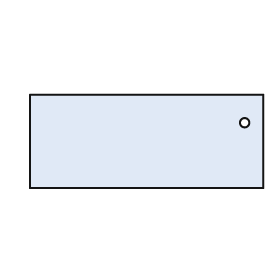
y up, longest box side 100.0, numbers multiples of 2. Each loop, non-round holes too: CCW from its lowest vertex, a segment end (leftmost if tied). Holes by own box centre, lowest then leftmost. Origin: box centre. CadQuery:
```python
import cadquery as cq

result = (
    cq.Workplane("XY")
    .moveTo(-50.0, -20.0)
    .lineTo(50.0, -20.0)
    .lineTo(50.0, 20.0)
    .lineTo(-50.0, 20.0)
    .close()
    .moveTo(42.0, 8.0)
    .circle(2.0)
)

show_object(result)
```